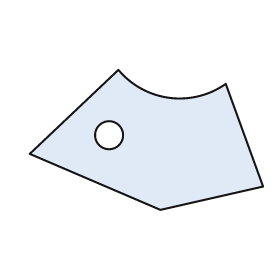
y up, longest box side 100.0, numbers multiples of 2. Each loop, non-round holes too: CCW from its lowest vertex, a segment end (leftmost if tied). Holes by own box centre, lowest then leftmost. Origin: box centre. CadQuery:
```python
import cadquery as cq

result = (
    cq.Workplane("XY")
    .moveTo(6.0, -30.0)
    .lineTo(50.0, -20.0)
    .lineTo(34.0, 24.0)
    .threePointArc((10.0, 18.0), (-12.0, 30.0))
    .lineTo(-50.0, -6.0)
    .close()
    .moveTo(-16.0, 2.0)
    .circle(6.0)
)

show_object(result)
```